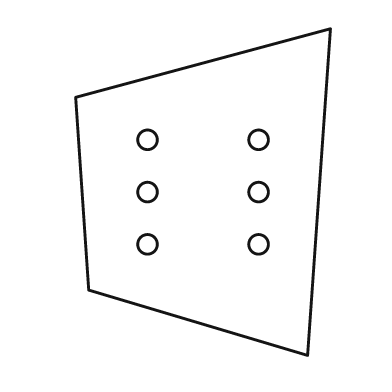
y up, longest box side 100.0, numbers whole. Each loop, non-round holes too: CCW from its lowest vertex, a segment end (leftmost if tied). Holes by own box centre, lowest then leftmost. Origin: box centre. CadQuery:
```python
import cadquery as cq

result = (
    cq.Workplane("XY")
    .moveTo(32.0, -50.0)
    .lineTo(39.0, 50.0)
    .lineTo(-39.0, 29.0)
    .lineTo(-35.0, -30.0)
    .close()
    .moveTo(-17.0, -16.0)
    .circle(3.0)
    .moveTo(17.0, -16.0)
    .circle(3.0)
    .moveTo(-17.0, 0.0)
    .circle(3.0)
    .moveTo(17.0, 0.0)
    .circle(3.0)
    .moveTo(-17.0, 16.0)
    .circle(3.0)
    .moveTo(17.0, 16.0)
    .circle(3.0)
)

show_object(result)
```